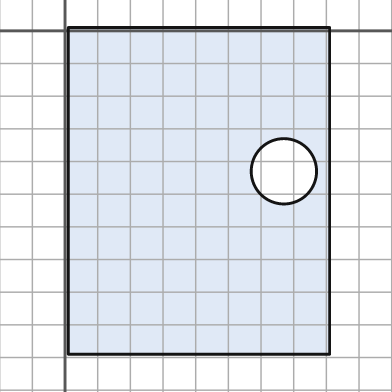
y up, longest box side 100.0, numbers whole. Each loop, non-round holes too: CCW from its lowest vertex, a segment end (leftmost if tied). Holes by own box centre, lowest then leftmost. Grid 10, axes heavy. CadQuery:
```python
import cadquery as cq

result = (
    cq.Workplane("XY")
    .moveTo(1.0, -99.0)
    .lineTo(81.0, -99.0)
    .lineTo(81.0, 1.0)
    .lineTo(1.0, 1.0)
    .close()
    .moveTo(67.0, -43.0)
    .circle(10.0)
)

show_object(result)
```